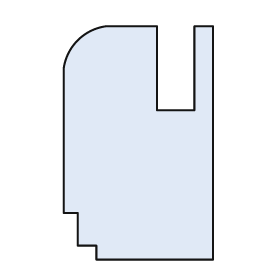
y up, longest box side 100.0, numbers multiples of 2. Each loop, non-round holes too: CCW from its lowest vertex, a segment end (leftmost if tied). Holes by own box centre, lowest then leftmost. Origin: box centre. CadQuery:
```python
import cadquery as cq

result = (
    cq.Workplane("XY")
    .moveTo(-18.0, -50.0)
    .lineTo(32.0, -50.0)
    .lineTo(32.0, 50.0)
    .lineTo(24.0, 50.0)
    .lineTo(24.0, 14.0)
    .lineTo(8.0, 14.0)
    .lineTo(8.0, 50.0)
    .lineTo(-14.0, 50.0)
    .threePointArc((-26.0, 44.0), (-32.0, 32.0))
    .lineTo(-32.0, -30.0)
    .lineTo(-26.0, -30.0)
    .lineTo(-26.0, -44.0)
    .lineTo(-18.0, -44.0)
    .close()
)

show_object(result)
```